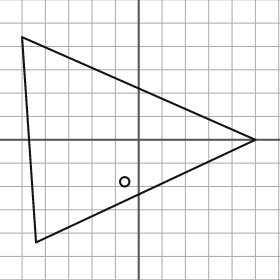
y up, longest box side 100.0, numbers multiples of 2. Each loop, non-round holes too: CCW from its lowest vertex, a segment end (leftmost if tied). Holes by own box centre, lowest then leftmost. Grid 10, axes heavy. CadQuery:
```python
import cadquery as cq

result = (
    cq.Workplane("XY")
    .moveTo(-44.0, -44.0)
    .lineTo(50.0, 0.0)
    .lineTo(-50.0, 44.0)
    .close()
    .moveTo(-6.0, -18.0)
    .circle(2.0)
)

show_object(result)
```